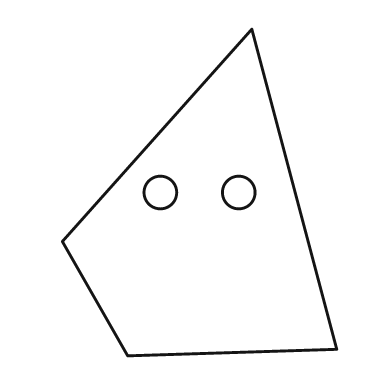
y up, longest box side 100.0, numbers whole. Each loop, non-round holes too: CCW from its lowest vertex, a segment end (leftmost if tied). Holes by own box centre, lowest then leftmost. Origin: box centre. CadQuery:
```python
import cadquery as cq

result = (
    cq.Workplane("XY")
    .moveTo(-22.0, -50.0)
    .lineTo(42.0, -48.0)
    .lineTo(16.0, 50.0)
    .lineTo(-42.0, -15.0)
    .close()
    .moveTo(-12.0, 0.0)
    .circle(5.0)
    .moveTo(12.0, 0.0)
    .circle(5.0)
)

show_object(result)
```